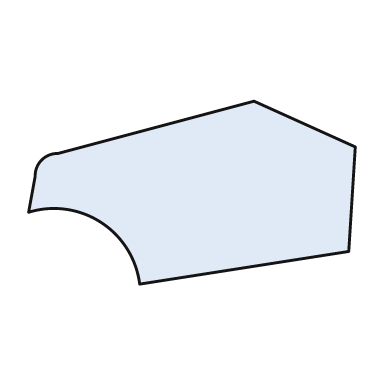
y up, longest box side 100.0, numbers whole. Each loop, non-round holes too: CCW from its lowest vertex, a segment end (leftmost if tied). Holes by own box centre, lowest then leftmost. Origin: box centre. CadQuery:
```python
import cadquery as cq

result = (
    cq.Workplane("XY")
    .moveTo(-16.0, -28.0)
    .lineTo(48.0, -18.0)
    .lineTo(50.0, 14.0)
    .lineTo(19.0, 28.0)
    .lineTo(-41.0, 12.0)
    .threePointArc((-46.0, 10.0), (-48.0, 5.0))
    .lineTo(-50.0, -6.0)
    .threePointArc((-28.0, -9.0), (-16.0, -28.0))
    .close()
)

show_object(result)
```